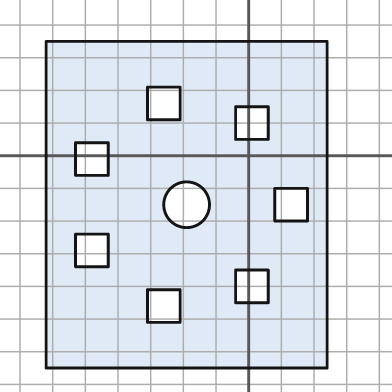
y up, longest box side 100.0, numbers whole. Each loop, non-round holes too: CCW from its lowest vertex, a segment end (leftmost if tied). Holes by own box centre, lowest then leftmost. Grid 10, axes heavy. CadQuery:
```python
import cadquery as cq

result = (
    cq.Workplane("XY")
    .moveTo(-62.0, -65.0)
    .lineTo(24.0, -65.0)
    .lineTo(24.0, 35.0)
    .lineTo(-62.0, 35.0)
    .close()
    .moveTo(-31.0, -51.0)
    .lineTo(-21.0, -51.0)
    .lineTo(-21.0, -41.0)
    .lineTo(-31.0, -41.0)
    .close()
    .moveTo(-4.0, -45.0)
    .lineTo(6.0, -45.0)
    .lineTo(6.0, -35.0)
    .lineTo(-4.0, -35.0)
    .close()
    .moveTo(-53.0, -34.0)
    .lineTo(-43.0, -34.0)
    .lineTo(-43.0, -24.0)
    .lineTo(-53.0, -24.0)
    .close()
    .moveTo(-19.0, -15.0)
    .circle(7.0)
    .moveTo(8.0, -20.0)
    .lineTo(18.0, -20.0)
    .lineTo(18.0, -10.0)
    .lineTo(8.0, -10.0)
    .close()
    .moveTo(-53.0, -6.0)
    .lineTo(-43.0, -6.0)
    .lineTo(-43.0, 4.0)
    .lineTo(-53.0, 4.0)
    .close()
    .moveTo(-4.0, 5.0)
    .lineTo(6.0, 5.0)
    .lineTo(6.0, 15.0)
    .lineTo(-4.0, 15.0)
    .close()
    .moveTo(-31.0, 11.0)
    .lineTo(-21.0, 11.0)
    .lineTo(-21.0, 21.0)
    .lineTo(-31.0, 21.0)
    .close()
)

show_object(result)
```